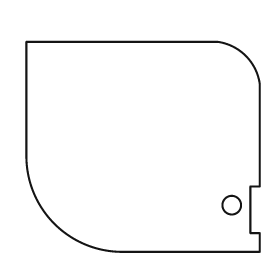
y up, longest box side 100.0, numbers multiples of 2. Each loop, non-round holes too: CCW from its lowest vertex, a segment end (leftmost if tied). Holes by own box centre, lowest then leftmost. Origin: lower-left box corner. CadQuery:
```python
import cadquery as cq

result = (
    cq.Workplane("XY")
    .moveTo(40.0, 0.0)
    .lineTo(100.0, 0.0)
    .lineTo(100.0, 8.0)
    .lineTo(96.0, 8.0)
    .lineTo(96.0, 28.0)
    .lineTo(100.0, 28.0)
    .lineTo(100.0, 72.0)
    .threePointArc((94.0, 84.0), (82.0, 90.0))
    .lineTo(0.0, 90.0)
    .lineTo(0.0, 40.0)
    .threePointArc((12.0, 12.0), (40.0, 0.0))
    .close()
    .moveTo(88.0, 20.0)
    .circle(4.0)
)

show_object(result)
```